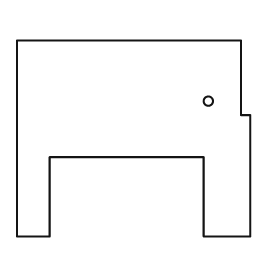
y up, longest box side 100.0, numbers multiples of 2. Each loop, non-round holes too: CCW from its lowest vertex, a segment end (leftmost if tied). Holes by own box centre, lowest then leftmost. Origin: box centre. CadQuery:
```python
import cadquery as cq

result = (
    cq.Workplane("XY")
    .moveTo(-50.0, -42.0)
    .lineTo(-36.0, -42.0)
    .lineTo(-36.0, -8.0)
    .lineTo(30.0, -8.0)
    .lineTo(30.0, -42.0)
    .lineTo(50.0, -42.0)
    .lineTo(50.0, 10.0)
    .lineTo(46.0, 10.0)
    .lineTo(46.0, 42.0)
    .lineTo(-50.0, 42.0)
    .close()
    .moveTo(32.0, 16.0)
    .circle(2.0)
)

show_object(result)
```